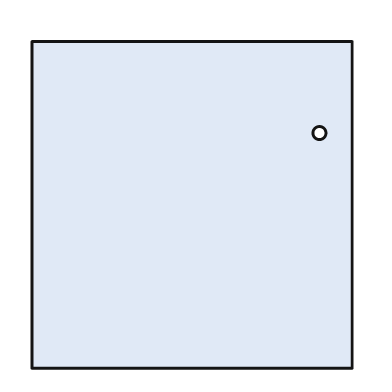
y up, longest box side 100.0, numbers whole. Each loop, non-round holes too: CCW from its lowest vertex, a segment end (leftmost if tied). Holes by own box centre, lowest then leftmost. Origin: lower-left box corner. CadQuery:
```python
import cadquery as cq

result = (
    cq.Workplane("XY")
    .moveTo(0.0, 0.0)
    .lineTo(98.0, 0.0)
    .lineTo(98.0, 100.0)
    .lineTo(0.0, 100.0)
    .close()
    .moveTo(88.0, 72.0)
    .circle(2.0)
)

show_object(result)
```